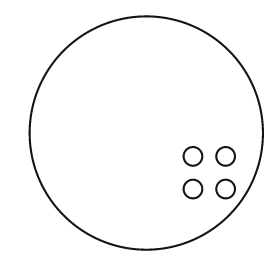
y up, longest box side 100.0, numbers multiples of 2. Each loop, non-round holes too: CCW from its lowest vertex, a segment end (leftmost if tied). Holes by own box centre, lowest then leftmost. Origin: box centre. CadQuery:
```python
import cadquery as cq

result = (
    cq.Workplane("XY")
    .moveTo(0.0, 0.0)
    .circle(50.0)
    .moveTo(20.0, -24.0)
    .circle(4.0)
    .moveTo(34.0, -24.0)
    .circle(4.0)
    .moveTo(20.0, -10.0)
    .circle(4.0)
    .moveTo(34.0, -10.0)
    .circle(4.0)
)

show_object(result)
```